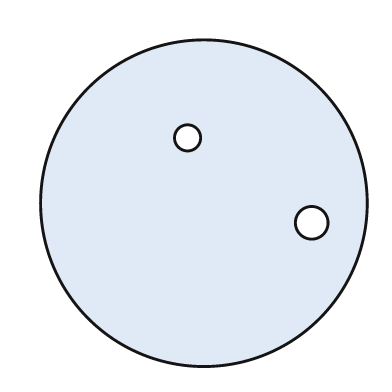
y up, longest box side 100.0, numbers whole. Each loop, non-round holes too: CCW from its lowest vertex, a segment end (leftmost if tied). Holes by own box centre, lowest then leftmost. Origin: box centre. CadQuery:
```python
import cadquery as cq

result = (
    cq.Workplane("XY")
    .moveTo(0.0, 0.0)
    .circle(50.0)
    .moveTo(33.0, -6.0)
    .circle(5.0)
    .moveTo(-5.0, 20.0)
    .circle(4.0)
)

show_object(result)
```